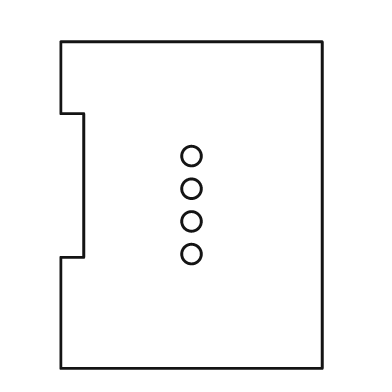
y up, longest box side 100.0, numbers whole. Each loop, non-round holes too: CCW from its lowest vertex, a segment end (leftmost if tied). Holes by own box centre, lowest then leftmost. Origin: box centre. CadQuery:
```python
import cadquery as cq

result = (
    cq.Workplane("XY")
    .moveTo(-40.0, -50.0)
    .lineTo(40.0, -50.0)
    .lineTo(40.0, 50.0)
    .lineTo(-40.0, 50.0)
    .lineTo(-40.0, 28.0)
    .lineTo(-33.0, 28.0)
    .lineTo(-33.0, -16.0)
    .lineTo(-40.0, -16.0)
    .close()
    .moveTo(0.0, -15.0)
    .circle(3.0)
    .moveTo(0.0, -5.0)
    .circle(3.0)
    .moveTo(0.0, 5.0)
    .circle(3.0)
    .moveTo(0.0, 15.0)
    .circle(3.0)
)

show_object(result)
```